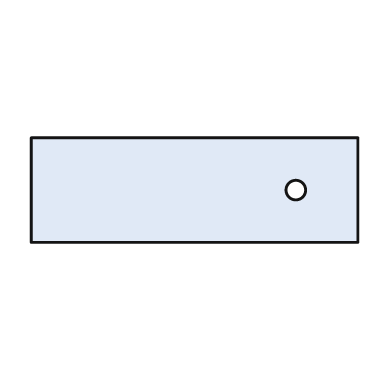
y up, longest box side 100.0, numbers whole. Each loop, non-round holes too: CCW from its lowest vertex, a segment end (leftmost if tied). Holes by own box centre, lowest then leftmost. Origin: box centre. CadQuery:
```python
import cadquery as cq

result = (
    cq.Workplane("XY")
    .moveTo(-50.0, -16.0)
    .lineTo(50.0, -16.0)
    .lineTo(50.0, 16.0)
    .lineTo(-50.0, 16.0)
    .close()
    .moveTo(31.0, 0.0)
    .circle(3.0)
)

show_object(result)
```